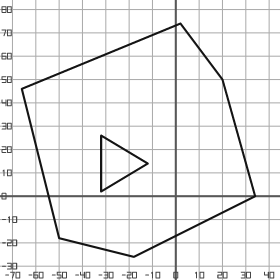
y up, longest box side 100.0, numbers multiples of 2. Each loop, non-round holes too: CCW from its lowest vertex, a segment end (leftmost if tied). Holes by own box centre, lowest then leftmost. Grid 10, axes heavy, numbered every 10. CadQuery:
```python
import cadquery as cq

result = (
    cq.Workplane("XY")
    .moveTo(-18.0, -26.0)
    .lineTo(34.0, 0.0)
    .lineTo(20.0, 50.0)
    .lineTo(2.0, 74.0)
    .lineTo(-66.0, 46.0)
    .lineTo(-50.0, -18.0)
    .close()
    .moveTo(-32.0, 2.0)
    .lineTo(-12.0, 14.0)
    .lineTo(-32.0, 26.0)
    .close()
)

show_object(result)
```